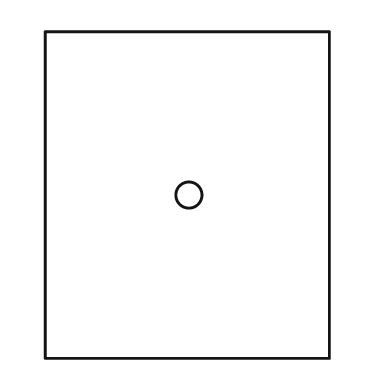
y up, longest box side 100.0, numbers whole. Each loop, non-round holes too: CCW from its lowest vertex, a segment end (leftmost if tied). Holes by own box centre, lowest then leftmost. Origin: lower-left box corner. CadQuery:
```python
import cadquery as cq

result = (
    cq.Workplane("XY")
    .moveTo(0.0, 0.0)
    .lineTo(87.0, 0.0)
    .lineTo(87.0, 100.0)
    .lineTo(0.0, 100.0)
    .close()
    .moveTo(44.0, 50.0)
    .circle(4.0)
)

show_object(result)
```